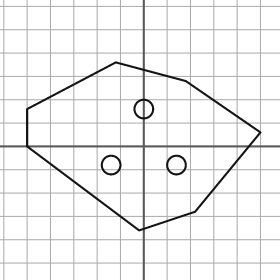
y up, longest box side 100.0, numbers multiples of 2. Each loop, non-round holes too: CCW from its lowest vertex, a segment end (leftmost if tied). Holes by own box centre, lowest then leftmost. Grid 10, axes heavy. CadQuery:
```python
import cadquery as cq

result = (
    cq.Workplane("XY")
    .moveTo(-2.0, -36.0)
    .lineTo(22.0, -28.0)
    .lineTo(50.0, 6.0)
    .lineTo(18.0, 28.0)
    .lineTo(-12.0, 36.0)
    .lineTo(-50.0, 16.0)
    .lineTo(-50.0, 0.0)
    .close()
    .moveTo(-14.0, -8.0)
    .circle(4.0)
    .moveTo(14.0, -8.0)
    .circle(4.0)
    .moveTo(0.0, 16.0)
    .circle(4.0)
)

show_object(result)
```